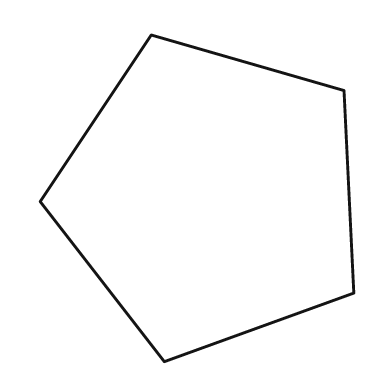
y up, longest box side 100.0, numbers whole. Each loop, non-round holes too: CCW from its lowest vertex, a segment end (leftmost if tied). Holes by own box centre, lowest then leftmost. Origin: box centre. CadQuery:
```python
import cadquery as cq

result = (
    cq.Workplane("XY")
    .moveTo(-10.0, -50.0)
    .lineTo(48.0, -29.0)
    .lineTo(45.0, 33.0)
    .lineTo(-14.0, 50.0)
    .lineTo(-48.0, -1.0)
    .close()
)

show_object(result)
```